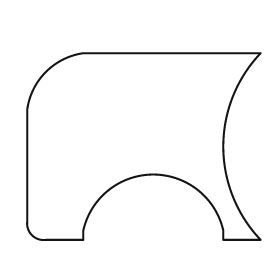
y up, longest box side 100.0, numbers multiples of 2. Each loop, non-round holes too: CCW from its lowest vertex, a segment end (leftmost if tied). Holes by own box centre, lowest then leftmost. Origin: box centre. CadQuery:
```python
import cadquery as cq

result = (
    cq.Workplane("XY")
    .moveTo(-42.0, -40.0)
    .lineTo(-26.0, -40.0)
    .lineTo(-26.0, -36.0)
    .threePointArc((4.0, -12.0), (34.0, -36.0))
    .lineTo(34.0, -40.0)
    .lineTo(50.0, -40.0)
    .threePointArc((34.0, 0.0), (50.0, 40.0))
    .lineTo(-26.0, 40.0)
    .threePointArc((-42.0, 32.0), (-50.0, 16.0))
    .lineTo(-50.0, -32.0)
    .threePointArc((-48.0, -38.0), (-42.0, -40.0))
    .close()
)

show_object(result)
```